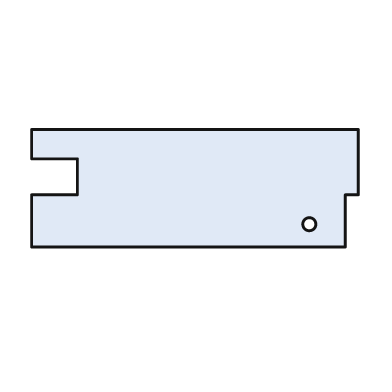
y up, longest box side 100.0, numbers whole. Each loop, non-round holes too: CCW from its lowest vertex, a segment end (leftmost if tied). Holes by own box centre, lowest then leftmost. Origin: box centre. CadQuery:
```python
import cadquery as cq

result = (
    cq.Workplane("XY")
    .moveTo(-50.0, -18.0)
    .lineTo(46.0, -18.0)
    .lineTo(46.0, -2.0)
    .lineTo(50.0, -2.0)
    .lineTo(50.0, 18.0)
    .lineTo(-50.0, 18.0)
    .lineTo(-50.0, 9.0)
    .lineTo(-36.0, 9.0)
    .lineTo(-36.0, -2.0)
    .lineTo(-50.0, -2.0)
    .close()
    .moveTo(35.0, -11.0)
    .circle(2.0)
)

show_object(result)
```